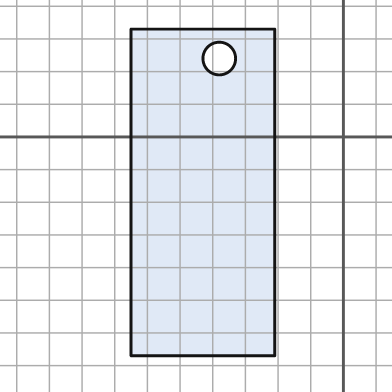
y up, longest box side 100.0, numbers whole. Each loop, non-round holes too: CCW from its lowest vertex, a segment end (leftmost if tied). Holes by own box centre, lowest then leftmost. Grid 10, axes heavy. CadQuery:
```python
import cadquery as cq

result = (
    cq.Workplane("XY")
    .moveTo(-65.0, -67.0)
    .lineTo(-21.0, -67.0)
    .lineTo(-21.0, 33.0)
    .lineTo(-65.0, 33.0)
    .close()
    .moveTo(-38.0, 24.0)
    .circle(5.0)
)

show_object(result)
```